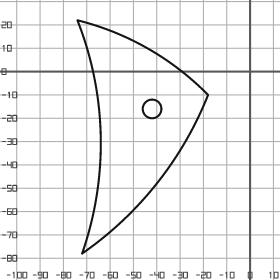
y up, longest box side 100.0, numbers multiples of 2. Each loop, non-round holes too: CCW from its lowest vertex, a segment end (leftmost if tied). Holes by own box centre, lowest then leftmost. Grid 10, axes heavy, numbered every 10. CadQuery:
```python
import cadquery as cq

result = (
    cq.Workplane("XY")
    .moveTo(-72.0, -78.0)
    .threePointArc((-40.0, -48.0), (-18.0, -10.0))
    .threePointArc((-44.0, 10.0), (-74.0, 22.0))
    .threePointArc((-64.0, -28.0), (-72.0, -78.0))
    .close()
    .moveTo(-42.0, -16.0)
    .circle(4.0)
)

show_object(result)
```